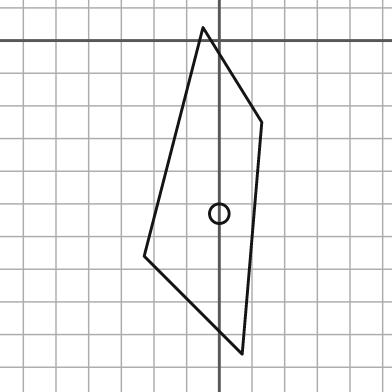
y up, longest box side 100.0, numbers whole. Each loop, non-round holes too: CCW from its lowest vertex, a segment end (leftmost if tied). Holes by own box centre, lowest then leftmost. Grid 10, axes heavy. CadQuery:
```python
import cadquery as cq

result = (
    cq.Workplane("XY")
    .moveTo(7.0, -96.0)
    .lineTo(13.0, -25.0)
    .lineTo(-5.0, 4.0)
    .lineTo(-23.0, -66.0)
    .close()
    .moveTo(0.0, -53.0)
    .circle(3.0)
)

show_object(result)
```